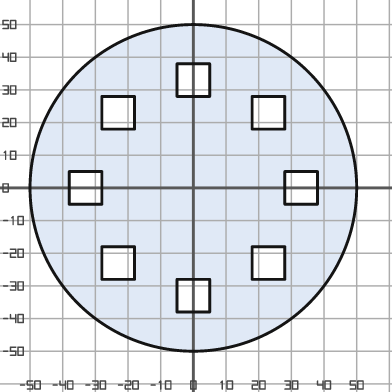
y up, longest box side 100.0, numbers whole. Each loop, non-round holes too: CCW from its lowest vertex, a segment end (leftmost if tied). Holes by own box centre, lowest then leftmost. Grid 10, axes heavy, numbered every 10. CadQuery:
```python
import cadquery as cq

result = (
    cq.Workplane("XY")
    .moveTo(0.0, 0.0)
    .circle(50.0)
    .moveTo(-5.0, -38.0)
    .lineTo(5.0, -38.0)
    .lineTo(5.0, -28.0)
    .lineTo(-5.0, -28.0)
    .close()
    .moveTo(-28.0, -28.0)
    .lineTo(-18.0, -28.0)
    .lineTo(-18.0, -18.0)
    .lineTo(-28.0, -18.0)
    .close()
    .moveTo(18.0, -28.0)
    .lineTo(28.0, -28.0)
    .lineTo(28.0, -18.0)
    .lineTo(18.0, -18.0)
    .close()
    .moveTo(-38.0, -5.0)
    .lineTo(-28.0, -5.0)
    .lineTo(-28.0, 5.0)
    .lineTo(-38.0, 5.0)
    .close()
    .moveTo(28.0, -5.0)
    .lineTo(38.0, -5.0)
    .lineTo(38.0, 5.0)
    .lineTo(28.0, 5.0)
    .close()
    .moveTo(-28.0, 18.0)
    .lineTo(-18.0, 18.0)
    .lineTo(-18.0, 28.0)
    .lineTo(-28.0, 28.0)
    .close()
    .moveTo(18.0, 18.0)
    .lineTo(28.0, 18.0)
    .lineTo(28.0, 28.0)
    .lineTo(18.0, 28.0)
    .close()
    .moveTo(-5.0, 28.0)
    .lineTo(5.0, 28.0)
    .lineTo(5.0, 38.0)
    .lineTo(-5.0, 38.0)
    .close()
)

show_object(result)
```